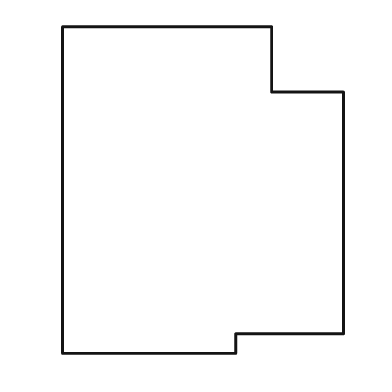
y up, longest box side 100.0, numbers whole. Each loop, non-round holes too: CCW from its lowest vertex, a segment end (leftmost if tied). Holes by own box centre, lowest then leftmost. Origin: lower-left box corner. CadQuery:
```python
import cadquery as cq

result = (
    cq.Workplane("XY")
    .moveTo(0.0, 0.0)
    .lineTo(53.0, 0.0)
    .lineTo(53.0, 6.0)
    .lineTo(86.0, 6.0)
    .lineTo(86.0, 80.0)
    .lineTo(64.0, 80.0)
    .lineTo(64.0, 100.0)
    .lineTo(0.0, 100.0)
    .close()
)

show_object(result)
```